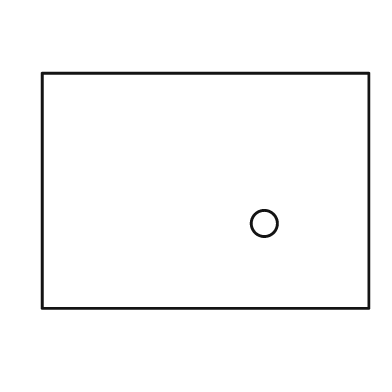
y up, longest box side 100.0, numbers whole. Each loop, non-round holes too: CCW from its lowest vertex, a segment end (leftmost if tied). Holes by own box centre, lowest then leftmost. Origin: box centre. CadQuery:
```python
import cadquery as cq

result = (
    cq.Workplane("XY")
    .moveTo(-50.0, -36.0)
    .lineTo(50.0, -36.0)
    .lineTo(50.0, 36.0)
    .lineTo(-50.0, 36.0)
    .close()
    .moveTo(18.0, -10.0)
    .circle(4.0)
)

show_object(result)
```